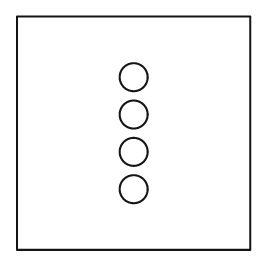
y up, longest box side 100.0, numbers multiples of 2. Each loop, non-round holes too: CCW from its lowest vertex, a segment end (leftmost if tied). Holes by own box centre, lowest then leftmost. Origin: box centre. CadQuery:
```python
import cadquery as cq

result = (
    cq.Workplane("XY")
    .moveTo(-50.0, -50.0)
    .lineTo(50.0, -50.0)
    .lineTo(50.0, 50.0)
    .lineTo(-50.0, 50.0)
    .close()
    .moveTo(0.0, -24.0)
    .circle(6.0)
    .moveTo(0.0, -8.0)
    .circle(6.0)
    .moveTo(0.0, 8.0)
    .circle(6.0)
    .moveTo(0.0, 24.0)
    .circle(6.0)
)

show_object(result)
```